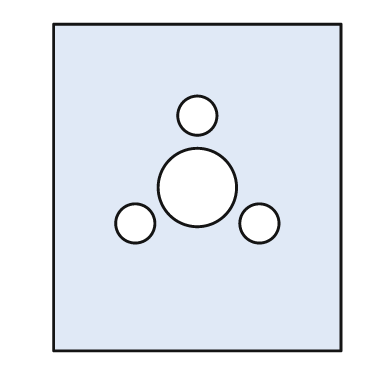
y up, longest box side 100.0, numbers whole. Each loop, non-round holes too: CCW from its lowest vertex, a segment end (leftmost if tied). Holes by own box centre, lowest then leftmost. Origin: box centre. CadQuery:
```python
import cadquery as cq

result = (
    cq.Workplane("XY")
    .moveTo(-44.0, -50.0)
    .lineTo(44.0, -50.0)
    .lineTo(44.0, 50.0)
    .lineTo(-44.0, 50.0)
    .close()
    .moveTo(-19.0, -11.0)
    .circle(6.0)
    .moveTo(19.0, -11.0)
    .circle(6.0)
    .moveTo(0.0, 0.0)
    .circle(12.0)
    .moveTo(0.0, 22.0)
    .circle(6.0)
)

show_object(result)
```